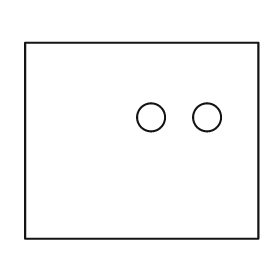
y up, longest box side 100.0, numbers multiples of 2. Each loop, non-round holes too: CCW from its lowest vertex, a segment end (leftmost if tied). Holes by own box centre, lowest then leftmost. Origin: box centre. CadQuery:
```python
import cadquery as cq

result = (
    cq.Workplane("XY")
    .moveTo(-50.0, -42.0)
    .lineTo(50.0, -42.0)
    .lineTo(50.0, 42.0)
    .lineTo(-50.0, 42.0)
    .close()
    .moveTo(4.0, 10.0)
    .circle(6.0)
    .moveTo(28.0, 10.0)
    .circle(6.0)
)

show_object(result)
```